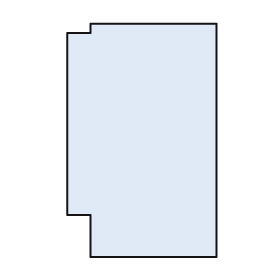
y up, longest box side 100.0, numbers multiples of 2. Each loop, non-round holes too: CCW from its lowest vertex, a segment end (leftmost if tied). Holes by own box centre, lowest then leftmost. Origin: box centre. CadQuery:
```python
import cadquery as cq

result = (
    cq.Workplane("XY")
    .moveTo(-22.0, -50.0)
    .lineTo(32.0, -50.0)
    .lineTo(32.0, 50.0)
    .lineTo(-22.0, 50.0)
    .lineTo(-22.0, 46.0)
    .lineTo(-32.0, 46.0)
    .lineTo(-32.0, -32.0)
    .lineTo(-22.0, -32.0)
    .close()
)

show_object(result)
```